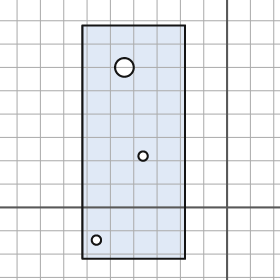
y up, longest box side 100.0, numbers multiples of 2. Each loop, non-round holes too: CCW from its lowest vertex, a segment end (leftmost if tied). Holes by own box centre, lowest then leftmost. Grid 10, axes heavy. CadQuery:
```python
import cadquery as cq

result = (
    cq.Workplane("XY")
    .moveTo(-62.0, -22.0)
    .lineTo(-18.0, -22.0)
    .lineTo(-18.0, 78.0)
    .lineTo(-62.0, 78.0)
    .close()
    .moveTo(-56.0, -14.0)
    .circle(2.0)
    .moveTo(-36.0, 22.0)
    .circle(2.0)
    .moveTo(-44.0, 60.0)
    .circle(4.0)
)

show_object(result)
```